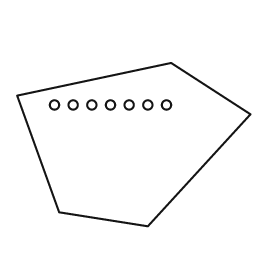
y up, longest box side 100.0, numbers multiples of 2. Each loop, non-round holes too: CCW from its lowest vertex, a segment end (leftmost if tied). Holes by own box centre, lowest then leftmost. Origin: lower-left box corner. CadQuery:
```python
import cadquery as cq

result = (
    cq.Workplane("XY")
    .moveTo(56.0, 0.0)
    .lineTo(100.0, 48.0)
    .lineTo(66.0, 70.0)
    .lineTo(0.0, 56.0)
    .lineTo(18.0, 6.0)
    .close()
    .moveTo(16.0, 52.0)
    .circle(2.0)
    .moveTo(24.0, 52.0)
    .circle(2.0)
    .moveTo(32.0, 52.0)
    .circle(2.0)
    .moveTo(40.0, 52.0)
    .circle(2.0)
    .moveTo(48.0, 52.0)
    .circle(2.0)
    .moveTo(56.0, 52.0)
    .circle(2.0)
    .moveTo(64.0, 52.0)
    .circle(2.0)
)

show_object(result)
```